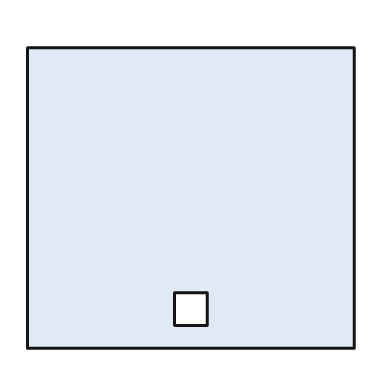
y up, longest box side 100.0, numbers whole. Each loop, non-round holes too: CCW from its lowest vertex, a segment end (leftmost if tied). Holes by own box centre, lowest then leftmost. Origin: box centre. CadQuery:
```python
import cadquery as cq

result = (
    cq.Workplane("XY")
    .moveTo(-50.0, -46.0)
    .lineTo(50.0, -46.0)
    .lineTo(50.0, 46.0)
    .lineTo(-50.0, 46.0)
    .close()
    .moveTo(-5.0, -39.0)
    .lineTo(5.0, -39.0)
    .lineTo(5.0, -29.0)
    .lineTo(-5.0, -29.0)
    .close()
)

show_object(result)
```